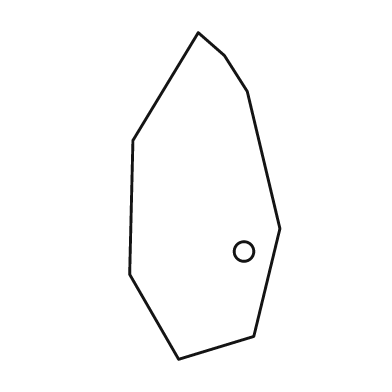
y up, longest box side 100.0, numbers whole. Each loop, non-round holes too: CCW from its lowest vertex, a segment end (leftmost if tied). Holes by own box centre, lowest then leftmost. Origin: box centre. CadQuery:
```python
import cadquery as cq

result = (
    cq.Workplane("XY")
    .moveTo(-8.0, -50.0)
    .lineTo(15.0, -43.0)
    .lineTo(23.0, -10.0)
    .lineTo(13.0, 32.0)
    .lineTo(6.0, 43.0)
    .lineTo(-2.0, 50.0)
    .lineTo(-22.0, 17.0)
    .lineTo(-23.0, -24.0)
    .close()
    .moveTo(12.0, -17.0)
    .circle(3.0)
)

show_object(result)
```